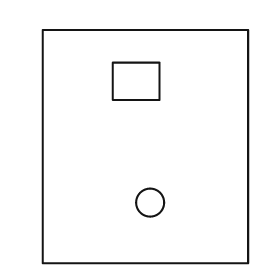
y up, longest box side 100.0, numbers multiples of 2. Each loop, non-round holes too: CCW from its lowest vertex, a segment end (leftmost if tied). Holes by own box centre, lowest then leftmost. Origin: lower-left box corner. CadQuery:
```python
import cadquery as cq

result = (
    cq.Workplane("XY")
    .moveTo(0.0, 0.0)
    .lineTo(88.0, 0.0)
    .lineTo(88.0, 100.0)
    .lineTo(0.0, 100.0)
    .close()
    .moveTo(46.0, 26.0)
    .circle(6.0)
    .moveTo(30.0, 70.0)
    .lineTo(50.0, 70.0)
    .lineTo(50.0, 86.0)
    .lineTo(30.0, 86.0)
    .close()
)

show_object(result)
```